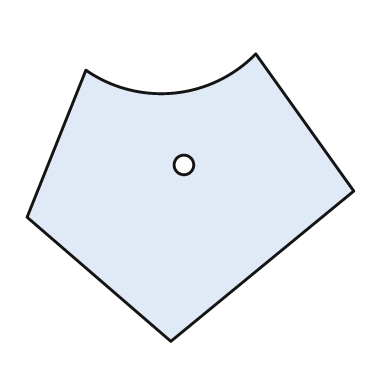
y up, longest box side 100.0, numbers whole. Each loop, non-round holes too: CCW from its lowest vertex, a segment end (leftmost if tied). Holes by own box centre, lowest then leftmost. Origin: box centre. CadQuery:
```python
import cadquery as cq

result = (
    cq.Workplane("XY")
    .moveTo(-6.0, -44.0)
    .lineTo(50.0, 2.0)
    .lineTo(20.0, 44.0)
    .threePointArc((-5.0, 32.0), (-32.0, 39.0))
    .lineTo(-50.0, -6.0)
    .close()
    .moveTo(-2.0, 10.0)
    .circle(3.0)
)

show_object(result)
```